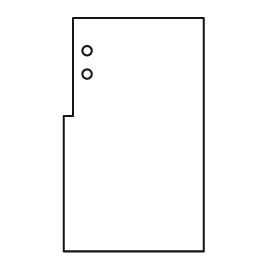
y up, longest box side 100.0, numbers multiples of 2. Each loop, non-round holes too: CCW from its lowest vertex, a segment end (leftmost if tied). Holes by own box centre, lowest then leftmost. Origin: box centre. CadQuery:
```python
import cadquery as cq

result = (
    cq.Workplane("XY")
    .moveTo(-30.0, -50.0)
    .lineTo(30.0, -50.0)
    .lineTo(30.0, 50.0)
    .lineTo(-26.0, 50.0)
    .lineTo(-26.0, 8.0)
    .lineTo(-30.0, 8.0)
    .close()
    .moveTo(-20.0, 26.0)
    .circle(2.0)
    .moveTo(-20.0, 36.0)
    .circle(2.0)
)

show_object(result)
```